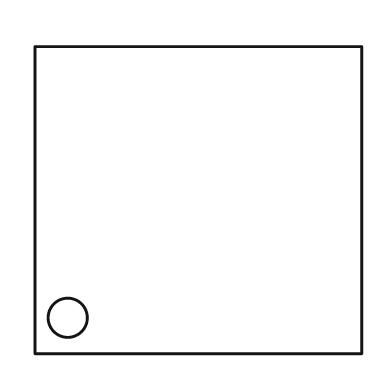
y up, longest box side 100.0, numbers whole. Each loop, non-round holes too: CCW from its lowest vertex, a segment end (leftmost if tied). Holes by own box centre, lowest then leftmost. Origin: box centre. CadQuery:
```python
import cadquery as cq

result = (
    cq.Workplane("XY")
    .moveTo(-50.0, -47.0)
    .lineTo(50.0, -47.0)
    .lineTo(50.0, 47.0)
    .lineTo(-50.0, 47.0)
    .close()
    .moveTo(-40.0, -36.0)
    .circle(6.0)
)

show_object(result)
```